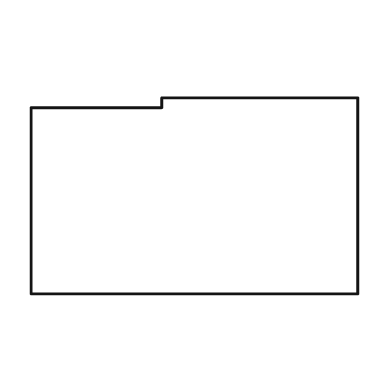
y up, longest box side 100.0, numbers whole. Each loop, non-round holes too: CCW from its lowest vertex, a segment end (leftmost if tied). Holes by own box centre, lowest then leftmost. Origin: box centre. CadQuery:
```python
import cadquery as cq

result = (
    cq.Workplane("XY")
    .moveTo(-50.0, -30.0)
    .lineTo(50.0, -30.0)
    .lineTo(50.0, 30.0)
    .lineTo(-10.0, 30.0)
    .lineTo(-10.0, 27.0)
    .lineTo(-50.0, 27.0)
    .close()
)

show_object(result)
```